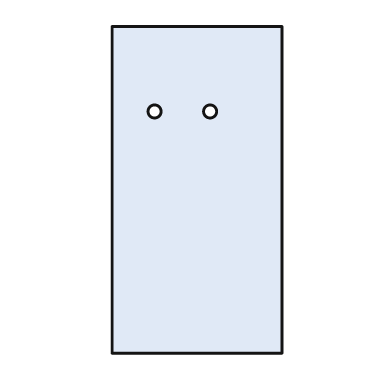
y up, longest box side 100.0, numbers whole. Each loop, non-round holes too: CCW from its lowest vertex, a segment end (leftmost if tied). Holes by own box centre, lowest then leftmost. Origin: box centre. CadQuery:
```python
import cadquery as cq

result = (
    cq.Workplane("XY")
    .moveTo(-26.0, -50.0)
    .lineTo(26.0, -50.0)
    .lineTo(26.0, 50.0)
    .lineTo(-26.0, 50.0)
    .close()
    .moveTo(-13.0, 24.0)
    .circle(2.0)
    .moveTo(4.0, 24.0)
    .circle(2.0)
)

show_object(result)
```